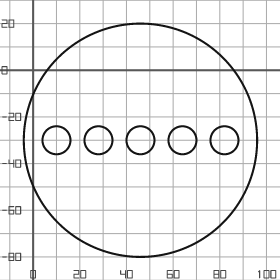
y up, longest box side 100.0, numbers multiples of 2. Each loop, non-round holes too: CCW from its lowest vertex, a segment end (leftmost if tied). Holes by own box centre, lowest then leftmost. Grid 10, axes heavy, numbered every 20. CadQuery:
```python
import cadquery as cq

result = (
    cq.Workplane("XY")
    .moveTo(46.0, -30.0)
    .circle(50.0)
    .moveTo(10.0, -30.0)
    .circle(6.0)
    .moveTo(28.0, -30.0)
    .circle(6.0)
    .moveTo(46.0, -30.0)
    .circle(6.0)
    .moveTo(64.0, -30.0)
    .circle(6.0)
    .moveTo(82.0, -30.0)
    .circle(6.0)
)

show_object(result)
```